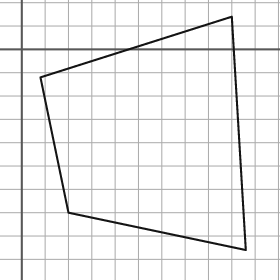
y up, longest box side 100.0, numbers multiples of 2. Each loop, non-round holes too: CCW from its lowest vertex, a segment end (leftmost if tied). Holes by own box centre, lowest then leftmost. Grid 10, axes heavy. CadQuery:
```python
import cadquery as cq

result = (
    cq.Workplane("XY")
    .moveTo(96.0, -86.0)
    .lineTo(90.0, 14.0)
    .lineTo(8.0, -12.0)
    .lineTo(20.0, -70.0)
    .close()
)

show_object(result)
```